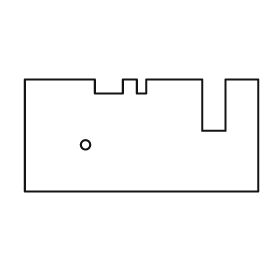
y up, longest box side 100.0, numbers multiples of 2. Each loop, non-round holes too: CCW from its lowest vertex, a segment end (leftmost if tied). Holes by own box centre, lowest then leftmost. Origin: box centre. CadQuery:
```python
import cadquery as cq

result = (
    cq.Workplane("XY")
    .moveTo(-50.0, -24.0)
    .lineTo(50.0, -24.0)
    .lineTo(50.0, 24.0)
    .lineTo(36.0, 24.0)
    .lineTo(36.0, 2.0)
    .lineTo(26.0, 2.0)
    .lineTo(26.0, 24.0)
    .lineTo(2.0, 24.0)
    .lineTo(2.0, 18.0)
    .lineTo(-2.0, 18.0)
    .lineTo(-2.0, 24.0)
    .lineTo(-8.0, 24.0)
    .lineTo(-8.0, 18.0)
    .lineTo(-20.0, 18.0)
    .lineTo(-20.0, 24.0)
    .lineTo(-50.0, 24.0)
    .close()
    .moveTo(-24.0, -4.0)
    .circle(2.0)
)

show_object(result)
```